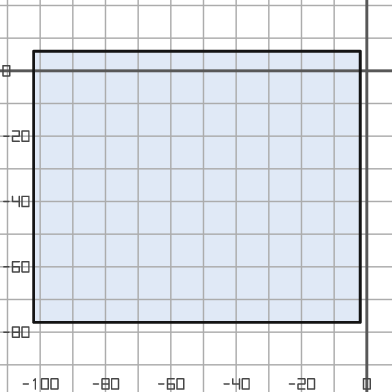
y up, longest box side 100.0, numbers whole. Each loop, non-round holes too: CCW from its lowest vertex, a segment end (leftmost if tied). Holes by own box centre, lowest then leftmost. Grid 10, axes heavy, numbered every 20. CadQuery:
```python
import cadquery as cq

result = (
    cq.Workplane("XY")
    .moveTo(-102.0, -77.0)
    .lineTo(-2.0, -77.0)
    .lineTo(-2.0, 6.0)
    .lineTo(-102.0, 6.0)
    .close()
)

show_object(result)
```